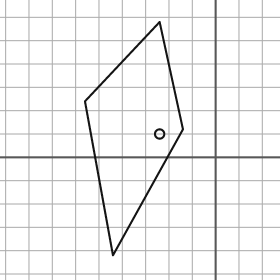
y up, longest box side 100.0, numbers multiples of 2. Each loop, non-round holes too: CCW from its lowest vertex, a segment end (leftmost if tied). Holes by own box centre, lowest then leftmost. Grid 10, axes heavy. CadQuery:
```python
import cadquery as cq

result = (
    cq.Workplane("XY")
    .moveTo(-44.0, -42.0)
    .lineTo(-14.0, 12.0)
    .lineTo(-24.0, 58.0)
    .lineTo(-56.0, 24.0)
    .close()
    .moveTo(-24.0, 10.0)
    .circle(2.0)
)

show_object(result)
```